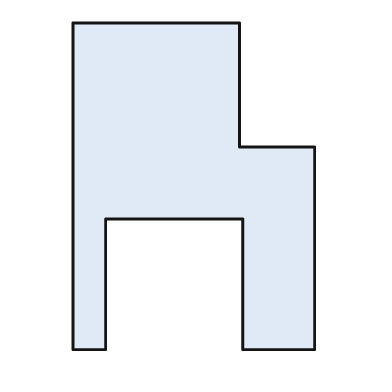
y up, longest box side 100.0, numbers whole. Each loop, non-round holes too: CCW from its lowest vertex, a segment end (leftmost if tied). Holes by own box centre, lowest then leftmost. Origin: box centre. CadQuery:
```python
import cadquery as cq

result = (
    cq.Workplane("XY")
    .moveTo(-37.0, -50.0)
    .lineTo(-27.0, -50.0)
    .lineTo(-27.0, -10.0)
    .lineTo(15.0, -10.0)
    .lineTo(15.0, -50.0)
    .lineTo(37.0, -50.0)
    .lineTo(37.0, 12.0)
    .lineTo(14.0, 12.0)
    .lineTo(14.0, 50.0)
    .lineTo(-37.0, 50.0)
    .close()
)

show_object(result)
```